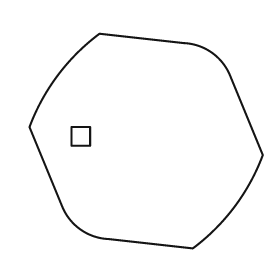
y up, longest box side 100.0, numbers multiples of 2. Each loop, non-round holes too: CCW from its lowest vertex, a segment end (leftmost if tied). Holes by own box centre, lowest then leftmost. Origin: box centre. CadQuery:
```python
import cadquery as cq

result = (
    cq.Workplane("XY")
    .moveTo(20.0, -46.0)
    .threePointArc((38.0, -28.0), (50.0, -6.0))
    .lineTo(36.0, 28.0)
    .threePointArc((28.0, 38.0), (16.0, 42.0))
    .lineTo(-20.0, 46.0)
    .threePointArc((-38.0, 28.0), (-50.0, 6.0))
    .lineTo(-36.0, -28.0)
    .threePointArc((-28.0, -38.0), (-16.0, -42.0))
    .close()
    .moveTo(-32.0, -2.0)
    .lineTo(-24.0, -2.0)
    .lineTo(-24.0, 6.0)
    .lineTo(-32.0, 6.0)
    .close()
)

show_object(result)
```